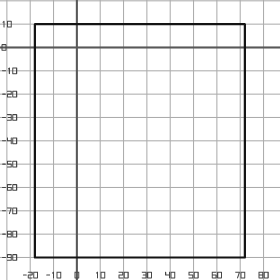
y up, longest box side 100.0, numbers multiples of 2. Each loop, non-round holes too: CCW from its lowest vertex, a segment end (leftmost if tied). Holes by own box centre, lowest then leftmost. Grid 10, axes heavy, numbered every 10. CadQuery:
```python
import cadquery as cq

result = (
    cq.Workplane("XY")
    .moveTo(-18.0, -90.0)
    .lineTo(72.0, -90.0)
    .lineTo(72.0, 10.0)
    .lineTo(-18.0, 10.0)
    .close()
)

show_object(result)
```